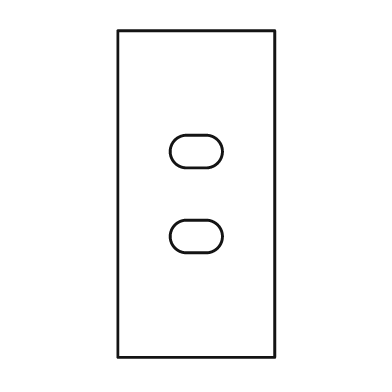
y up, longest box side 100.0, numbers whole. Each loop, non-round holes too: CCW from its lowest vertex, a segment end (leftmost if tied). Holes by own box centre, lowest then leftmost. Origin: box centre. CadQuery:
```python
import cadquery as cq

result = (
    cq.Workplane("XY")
    .moveTo(-24.0, -50.0)
    .lineTo(24.0, -50.0)
    .lineTo(24.0, 50.0)
    .lineTo(-24.0, 50.0)
    .close()
    .moveTo(-3.0, -18.0)
    .lineTo(3.0, -18.0)
    .threePointArc((8.0, -13.0), (3.0, -8.0))
    .lineTo(-3.0, -8.0)
    .threePointArc((-8.0, -13.0), (-3.0, -18.0))
    .close()
    .moveTo(-3.0, 8.0)
    .lineTo(3.0, 8.0)
    .threePointArc((8.0, 13.0), (3.0, 18.0))
    .lineTo(-3.0, 18.0)
    .threePointArc((-8.0, 13.0), (-3.0, 8.0))
    .close()
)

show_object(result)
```